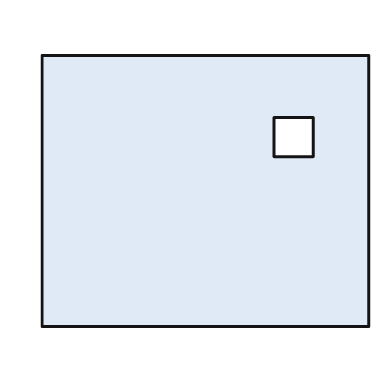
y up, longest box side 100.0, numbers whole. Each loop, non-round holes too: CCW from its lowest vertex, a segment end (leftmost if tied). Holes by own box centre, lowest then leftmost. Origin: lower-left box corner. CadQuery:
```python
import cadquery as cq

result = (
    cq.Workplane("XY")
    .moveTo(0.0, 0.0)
    .lineTo(100.0, 0.0)
    .lineTo(100.0, 83.0)
    .lineTo(0.0, 83.0)
    .close()
    .moveTo(71.0, 52.0)
    .lineTo(83.0, 52.0)
    .lineTo(83.0, 64.0)
    .lineTo(71.0, 64.0)
    .close()
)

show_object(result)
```